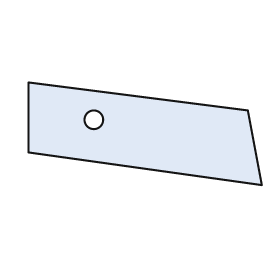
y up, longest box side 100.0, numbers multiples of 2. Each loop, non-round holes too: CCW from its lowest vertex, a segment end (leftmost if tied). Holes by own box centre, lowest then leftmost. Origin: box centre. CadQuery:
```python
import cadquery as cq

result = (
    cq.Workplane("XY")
    .moveTo(50.0, -22.0)
    .lineTo(44.0, 10.0)
    .lineTo(-50.0, 22.0)
    .lineTo(-50.0, -8.0)
    .close()
    .moveTo(-22.0, 6.0)
    .circle(4.0)
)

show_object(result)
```